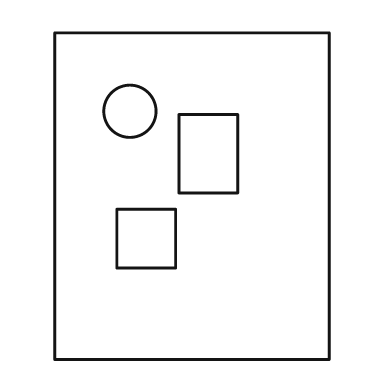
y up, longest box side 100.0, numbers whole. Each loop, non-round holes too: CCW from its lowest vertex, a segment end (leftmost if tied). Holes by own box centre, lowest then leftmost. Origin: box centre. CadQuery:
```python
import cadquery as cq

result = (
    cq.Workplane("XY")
    .moveTo(-42.0, -50.0)
    .lineTo(42.0, -50.0)
    .lineTo(42.0, 50.0)
    .lineTo(-42.0, 50.0)
    .close()
    .moveTo(-23.0, -22.0)
    .lineTo(-5.0, -22.0)
    .lineTo(-5.0, -4.0)
    .lineTo(-23.0, -4.0)
    .close()
    .moveTo(-4.0, 1.0)
    .lineTo(14.0, 1.0)
    .lineTo(14.0, 25.0)
    .lineTo(-4.0, 25.0)
    .close()
    .moveTo(-19.0, 26.0)
    .circle(8.0)
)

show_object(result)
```